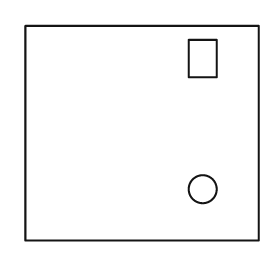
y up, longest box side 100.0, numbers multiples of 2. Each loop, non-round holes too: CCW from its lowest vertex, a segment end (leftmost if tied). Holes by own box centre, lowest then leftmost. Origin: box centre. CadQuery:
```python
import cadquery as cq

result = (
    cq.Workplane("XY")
    .moveTo(-50.0, -46.0)
    .lineTo(50.0, -46.0)
    .lineTo(50.0, 46.0)
    .lineTo(-50.0, 46.0)
    .close()
    .moveTo(26.0, -24.0)
    .circle(6.0)
    .moveTo(20.0, 24.0)
    .lineTo(32.0, 24.0)
    .lineTo(32.0, 40.0)
    .lineTo(20.0, 40.0)
    .close()
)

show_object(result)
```